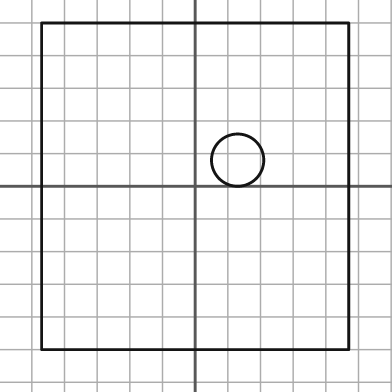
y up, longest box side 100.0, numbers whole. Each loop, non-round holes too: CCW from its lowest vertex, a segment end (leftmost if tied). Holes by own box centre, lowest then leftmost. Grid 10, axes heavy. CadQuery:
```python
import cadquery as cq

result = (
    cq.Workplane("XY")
    .moveTo(-47.0, -50.0)
    .lineTo(47.0, -50.0)
    .lineTo(47.0, 50.0)
    .lineTo(-47.0, 50.0)
    .close()
    .moveTo(13.0, 8.0)
    .circle(8.0)
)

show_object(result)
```